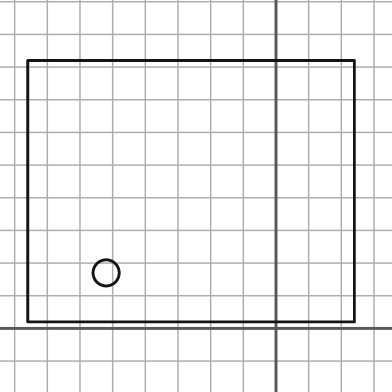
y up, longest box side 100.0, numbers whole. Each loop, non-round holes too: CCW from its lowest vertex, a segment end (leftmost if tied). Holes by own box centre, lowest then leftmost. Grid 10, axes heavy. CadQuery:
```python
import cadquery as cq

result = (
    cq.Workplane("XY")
    .moveTo(-76.0, 2.0)
    .lineTo(24.0, 2.0)
    .lineTo(24.0, 82.0)
    .lineTo(-76.0, 82.0)
    .close()
    .moveTo(-52.0, 17.0)
    .circle(4.0)
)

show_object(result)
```